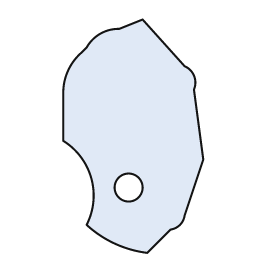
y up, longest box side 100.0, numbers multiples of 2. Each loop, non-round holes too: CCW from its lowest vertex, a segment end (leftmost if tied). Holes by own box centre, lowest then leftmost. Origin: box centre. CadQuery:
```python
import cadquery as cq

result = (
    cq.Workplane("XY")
    .moveTo(6.0, -50.0)
    .lineTo(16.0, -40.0)
    .threePointArc((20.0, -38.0), (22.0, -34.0))
    .lineTo(30.0, -10.0)
    .lineTo(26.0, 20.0)
    .threePointArc((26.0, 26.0), (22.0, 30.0))
    .lineTo(4.0, 50.0)
    .lineTo(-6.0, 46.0)
    .threePointArc((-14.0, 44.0), (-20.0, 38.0))
    .lineTo(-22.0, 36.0)
    .threePointArc((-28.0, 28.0), (-30.0, 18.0))
    .lineTo(-30.0, -2.0)
    .threePointArc((-18.0, -18.0), (-20.0, -38.0))
    .threePointArc((-8.0, -46.0), (6.0, -50.0))
    .close()
    .moveTo(-2.0, -22.0)
    .circle(6.0)
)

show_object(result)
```